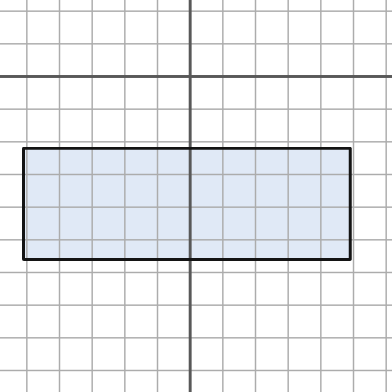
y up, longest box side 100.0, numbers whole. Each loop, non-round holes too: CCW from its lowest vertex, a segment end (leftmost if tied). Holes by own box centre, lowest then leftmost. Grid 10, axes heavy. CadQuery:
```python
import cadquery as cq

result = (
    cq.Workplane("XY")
    .moveTo(-51.0, -56.0)
    .lineTo(49.0, -56.0)
    .lineTo(49.0, -22.0)
    .lineTo(-51.0, -22.0)
    .close()
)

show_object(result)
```